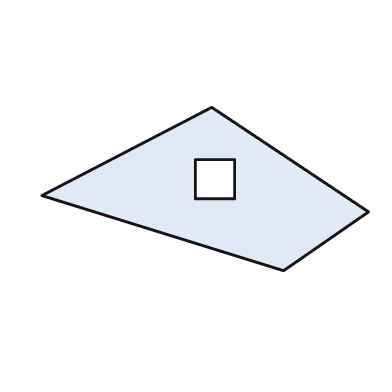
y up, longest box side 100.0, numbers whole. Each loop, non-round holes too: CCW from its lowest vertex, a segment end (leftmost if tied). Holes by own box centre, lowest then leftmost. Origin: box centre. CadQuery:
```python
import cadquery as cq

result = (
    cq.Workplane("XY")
    .moveTo(24.0, -25.0)
    .lineTo(50.0, -7.0)
    .lineTo(2.0, 25.0)
    .lineTo(-50.0, -2.0)
    .close()
    .moveTo(-3.0, -3.0)
    .lineTo(9.0, -3.0)
    .lineTo(9.0, 9.0)
    .lineTo(-3.0, 9.0)
    .close()
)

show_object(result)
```